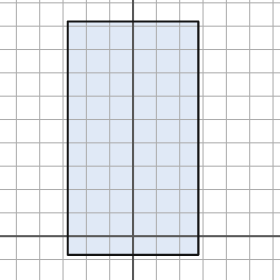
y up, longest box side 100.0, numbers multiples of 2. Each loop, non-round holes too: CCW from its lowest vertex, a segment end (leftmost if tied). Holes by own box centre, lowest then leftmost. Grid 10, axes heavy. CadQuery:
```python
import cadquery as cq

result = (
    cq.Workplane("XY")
    .moveTo(-28.0, -8.0)
    .lineTo(28.0, -8.0)
    .lineTo(28.0, 92.0)
    .lineTo(-28.0, 92.0)
    .close()
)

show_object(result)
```